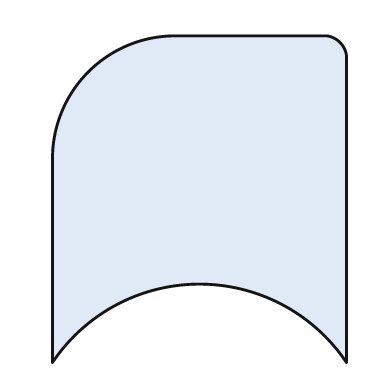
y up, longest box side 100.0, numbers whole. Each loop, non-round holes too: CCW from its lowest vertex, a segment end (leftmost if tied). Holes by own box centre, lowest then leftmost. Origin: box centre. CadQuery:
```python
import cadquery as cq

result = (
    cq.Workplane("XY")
    .moveTo(-45.0, -50.0)
    .threePointArc((0.0, -26.0), (45.0, -50.0))
    .lineTo(45.0, 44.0)
    .threePointArc((43.0, 48.0), (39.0, 50.0))
    .lineTo(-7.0, 50.0)
    .threePointArc((-34.0, 39.0), (-45.0, 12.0))
    .close()
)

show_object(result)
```